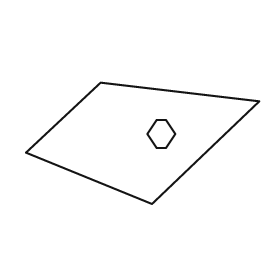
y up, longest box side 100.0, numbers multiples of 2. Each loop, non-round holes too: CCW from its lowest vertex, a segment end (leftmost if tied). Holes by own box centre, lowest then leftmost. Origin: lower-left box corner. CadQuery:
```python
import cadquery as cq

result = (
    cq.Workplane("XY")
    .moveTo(54.0, 0.0)
    .lineTo(100.0, 44.0)
    .lineTo(32.0, 52.0)
    .lineTo(0.0, 22.0)
    .close()
    .moveTo(56.0, 24.0)
    .lineTo(60.0, 24.0)
    .lineTo(64.0, 30.0)
    .lineTo(60.0, 36.0)
    .lineTo(56.0, 36.0)
    .lineTo(52.0, 30.0)
    .close()
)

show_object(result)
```